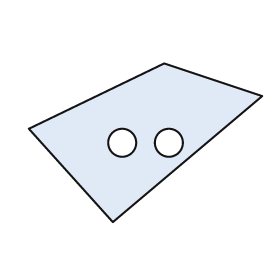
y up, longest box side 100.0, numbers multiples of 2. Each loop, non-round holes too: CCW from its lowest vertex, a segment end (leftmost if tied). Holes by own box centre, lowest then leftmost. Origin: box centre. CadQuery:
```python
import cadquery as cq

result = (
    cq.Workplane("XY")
    .moveTo(-14.0, -34.0)
    .lineTo(50.0, 20.0)
    .lineTo(8.0, 34.0)
    .lineTo(-50.0, 6.0)
    .close()
    .moveTo(-10.0, 0.0)
    .circle(6.0)
    .moveTo(10.0, 0.0)
    .circle(6.0)
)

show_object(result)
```